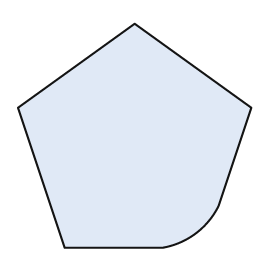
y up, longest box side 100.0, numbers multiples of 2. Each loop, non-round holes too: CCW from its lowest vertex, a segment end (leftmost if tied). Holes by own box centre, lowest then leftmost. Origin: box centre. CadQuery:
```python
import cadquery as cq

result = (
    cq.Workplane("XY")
    .moveTo(-30.0, -48.0)
    .lineTo(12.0, -48.0)
    .threePointArc((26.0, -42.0), (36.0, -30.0))
    .lineTo(50.0, 12.0)
    .lineTo(0.0, 48.0)
    .lineTo(-50.0, 12.0)
    .close()
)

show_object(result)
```